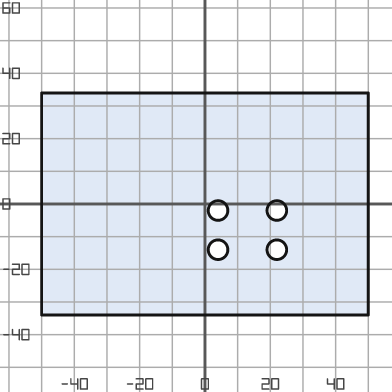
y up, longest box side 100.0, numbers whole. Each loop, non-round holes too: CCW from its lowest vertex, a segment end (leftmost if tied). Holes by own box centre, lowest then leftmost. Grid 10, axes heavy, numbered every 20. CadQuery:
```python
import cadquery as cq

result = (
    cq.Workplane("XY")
    .moveTo(-50.0, -34.0)
    .lineTo(50.0, -34.0)
    .lineTo(50.0, 34.0)
    .lineTo(-50.0, 34.0)
    .close()
    .moveTo(4.0, -14.0)
    .circle(3.0)
    .moveTo(22.0, -14.0)
    .circle(3.0)
    .moveTo(4.0, -2.0)
    .circle(3.0)
    .moveTo(22.0, -2.0)
    .circle(3.0)
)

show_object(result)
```